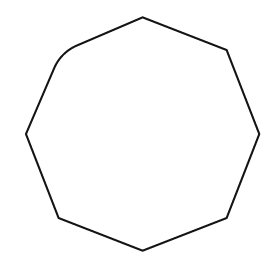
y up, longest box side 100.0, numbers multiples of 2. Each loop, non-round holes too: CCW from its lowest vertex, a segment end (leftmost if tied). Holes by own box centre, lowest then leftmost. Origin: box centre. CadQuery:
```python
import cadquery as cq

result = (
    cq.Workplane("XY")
    .moveTo(0.0, -50.0)
    .lineTo(36.0, -36.0)
    .lineTo(50.0, 0.0)
    .lineTo(36.0, 36.0)
    .lineTo(0.0, 50.0)
    .lineTo(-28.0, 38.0)
    .threePointArc((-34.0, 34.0), (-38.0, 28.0))
    .lineTo(-50.0, 0.0)
    .lineTo(-36.0, -36.0)
    .close()
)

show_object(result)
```